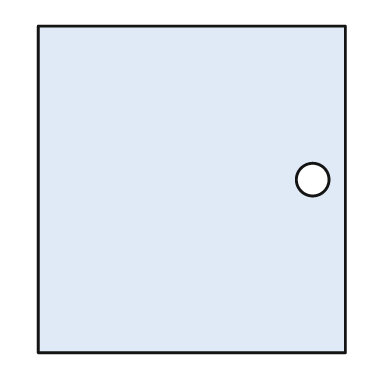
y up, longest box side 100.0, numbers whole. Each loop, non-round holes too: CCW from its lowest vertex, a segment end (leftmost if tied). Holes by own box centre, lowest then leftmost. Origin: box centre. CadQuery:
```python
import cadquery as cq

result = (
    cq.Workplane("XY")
    .moveTo(-47.0, -50.0)
    .lineTo(47.0, -50.0)
    .lineTo(47.0, 50.0)
    .lineTo(-47.0, 50.0)
    .close()
    .moveTo(37.0, 3.0)
    .circle(5.0)
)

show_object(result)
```